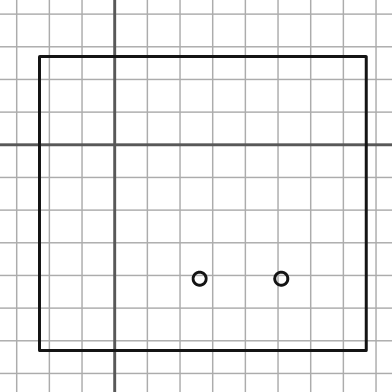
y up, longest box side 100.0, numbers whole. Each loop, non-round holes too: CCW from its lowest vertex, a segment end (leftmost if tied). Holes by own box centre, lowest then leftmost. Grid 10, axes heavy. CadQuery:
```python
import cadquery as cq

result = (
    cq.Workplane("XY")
    .moveTo(-23.0, -63.0)
    .lineTo(77.0, -63.0)
    .lineTo(77.0, 27.0)
    .lineTo(-23.0, 27.0)
    .close()
    .moveTo(26.0, -41.0)
    .circle(2.0)
    .moveTo(51.0, -41.0)
    .circle(2.0)
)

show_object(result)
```